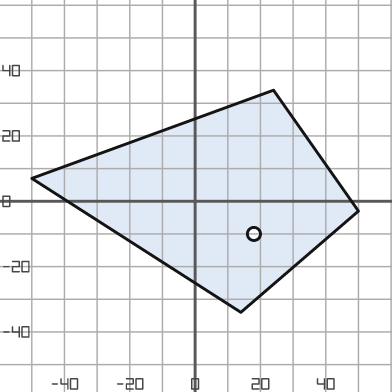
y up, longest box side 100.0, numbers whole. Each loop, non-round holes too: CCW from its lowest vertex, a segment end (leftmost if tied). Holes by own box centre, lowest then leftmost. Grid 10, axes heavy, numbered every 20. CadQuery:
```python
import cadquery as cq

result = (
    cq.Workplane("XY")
    .moveTo(14.0, -34.0)
    .lineTo(50.0, -3.0)
    .lineTo(24.0, 34.0)
    .lineTo(-50.0, 7.0)
    .close()
    .moveTo(18.0, -10.0)
    .circle(2.0)
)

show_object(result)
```